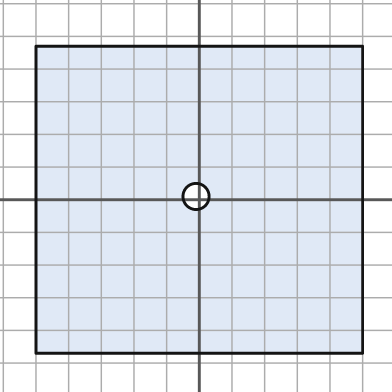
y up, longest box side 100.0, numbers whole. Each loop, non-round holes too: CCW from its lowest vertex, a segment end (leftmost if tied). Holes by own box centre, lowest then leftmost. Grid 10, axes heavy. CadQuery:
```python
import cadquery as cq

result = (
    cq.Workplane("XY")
    .moveTo(-50.0, -47.0)
    .lineTo(50.0, -47.0)
    .lineTo(50.0, 47.0)
    .lineTo(-50.0, 47.0)
    .close()
    .moveTo(-1.0, 1.0)
    .circle(4.0)
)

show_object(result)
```